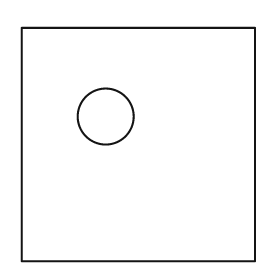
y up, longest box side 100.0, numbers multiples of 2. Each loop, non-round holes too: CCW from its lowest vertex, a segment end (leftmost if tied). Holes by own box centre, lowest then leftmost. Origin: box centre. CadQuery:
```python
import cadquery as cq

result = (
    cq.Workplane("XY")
    .moveTo(-50.0, -50.0)
    .lineTo(50.0, -50.0)
    .lineTo(50.0, 50.0)
    .lineTo(-50.0, 50.0)
    .close()
    .moveTo(-14.0, 12.0)
    .circle(12.0)
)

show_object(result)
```